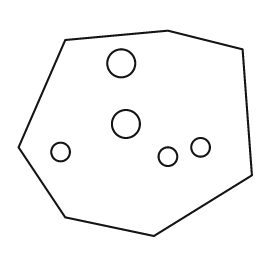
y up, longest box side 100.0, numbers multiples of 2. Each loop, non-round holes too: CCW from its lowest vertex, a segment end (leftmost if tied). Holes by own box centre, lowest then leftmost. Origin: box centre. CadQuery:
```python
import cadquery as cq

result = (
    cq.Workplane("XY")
    .moveTo(8.0, -44.0)
    .lineTo(50.0, -18.0)
    .lineTo(46.0, 36.0)
    .lineTo(14.0, 44.0)
    .lineTo(-30.0, 40.0)
    .lineTo(-50.0, -6.0)
    .lineTo(-30.0, -36.0)
    .close()
    .moveTo(14.0, -10.0)
    .circle(4.0)
    .moveTo(-32.0, -8.0)
    .circle(4.0)
    .moveTo(28.0, -6.0)
    .circle(4.0)
    .moveTo(-4.0, 4.0)
    .circle(6.0)
    .moveTo(-6.0, 30.0)
    .circle(6.0)
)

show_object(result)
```